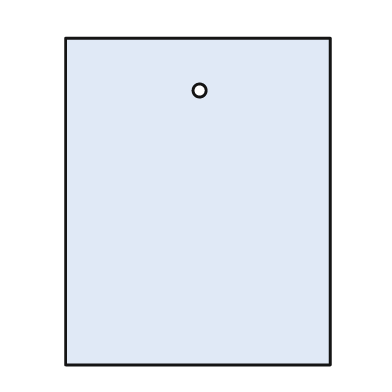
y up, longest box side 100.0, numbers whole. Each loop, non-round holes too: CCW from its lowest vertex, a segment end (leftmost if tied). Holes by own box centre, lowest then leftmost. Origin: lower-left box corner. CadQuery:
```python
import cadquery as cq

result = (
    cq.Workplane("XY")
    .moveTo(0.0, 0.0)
    .lineTo(81.0, 0.0)
    .lineTo(81.0, 100.0)
    .lineTo(0.0, 100.0)
    .close()
    .moveTo(41.0, 84.0)
    .circle(2.0)
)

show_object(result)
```